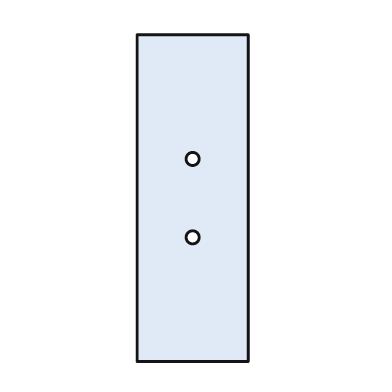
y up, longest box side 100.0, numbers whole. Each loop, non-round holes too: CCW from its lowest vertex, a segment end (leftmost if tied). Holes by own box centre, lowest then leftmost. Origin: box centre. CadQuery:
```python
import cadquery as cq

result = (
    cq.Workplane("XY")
    .moveTo(-17.0, -50.0)
    .lineTo(17.0, -50.0)
    .lineTo(17.0, 50.0)
    .lineTo(-17.0, 50.0)
    .close()
    .moveTo(0.0, -12.0)
    .circle(2.0)
    .moveTo(0.0, 12.0)
    .circle(2.0)
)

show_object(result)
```